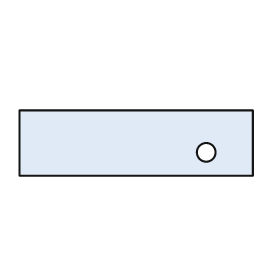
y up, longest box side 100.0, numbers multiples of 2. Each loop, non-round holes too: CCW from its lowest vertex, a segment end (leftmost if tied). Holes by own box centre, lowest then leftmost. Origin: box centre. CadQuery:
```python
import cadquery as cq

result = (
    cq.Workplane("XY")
    .moveTo(-50.0, -14.0)
    .lineTo(50.0, -14.0)
    .lineTo(50.0, 14.0)
    .lineTo(-50.0, 14.0)
    .close()
    .moveTo(30.0, -4.0)
    .circle(4.0)
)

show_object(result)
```